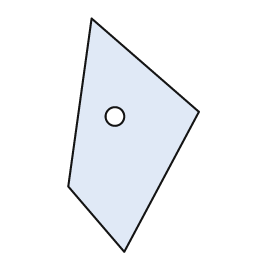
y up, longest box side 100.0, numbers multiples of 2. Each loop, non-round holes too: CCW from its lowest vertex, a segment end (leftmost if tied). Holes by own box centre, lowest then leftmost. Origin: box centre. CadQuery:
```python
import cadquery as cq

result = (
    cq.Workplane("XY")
    .moveTo(-4.0, -50.0)
    .lineTo(28.0, 10.0)
    .lineTo(-18.0, 50.0)
    .lineTo(-28.0, -22.0)
    .close()
    .moveTo(-8.0, 8.0)
    .circle(4.0)
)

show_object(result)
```